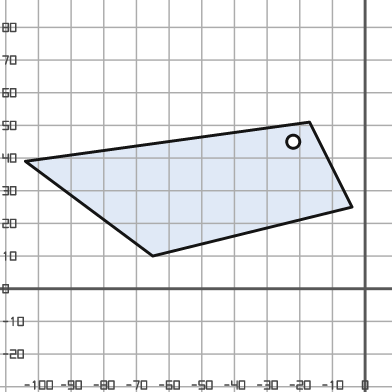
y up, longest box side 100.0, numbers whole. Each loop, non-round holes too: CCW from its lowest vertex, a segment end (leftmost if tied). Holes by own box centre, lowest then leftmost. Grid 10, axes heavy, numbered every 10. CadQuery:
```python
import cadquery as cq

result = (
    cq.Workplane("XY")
    .moveTo(-65.0, 10.0)
    .lineTo(-4.0, 25.0)
    .lineTo(-17.0, 51.0)
    .lineTo(-104.0, 39.0)
    .close()
    .moveTo(-22.0, 45.0)
    .circle(2.0)
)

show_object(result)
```